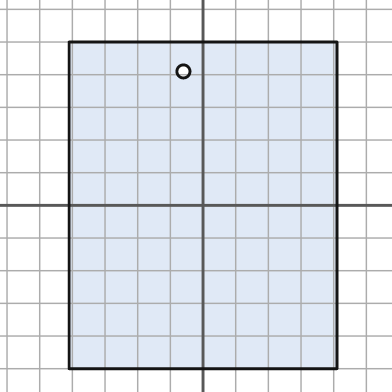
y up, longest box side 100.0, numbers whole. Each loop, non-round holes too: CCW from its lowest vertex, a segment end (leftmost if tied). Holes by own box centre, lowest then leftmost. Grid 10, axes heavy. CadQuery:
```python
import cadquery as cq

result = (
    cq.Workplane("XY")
    .moveTo(-41.0, -50.0)
    .lineTo(41.0, -50.0)
    .lineTo(41.0, 50.0)
    .lineTo(-41.0, 50.0)
    .close()
    .moveTo(-6.0, 41.0)
    .circle(2.0)
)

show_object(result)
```